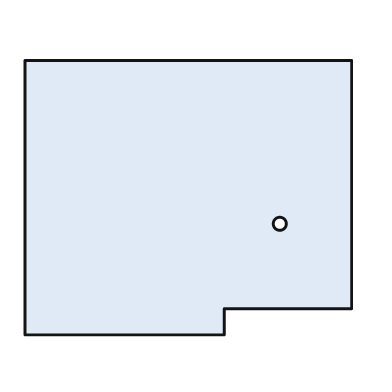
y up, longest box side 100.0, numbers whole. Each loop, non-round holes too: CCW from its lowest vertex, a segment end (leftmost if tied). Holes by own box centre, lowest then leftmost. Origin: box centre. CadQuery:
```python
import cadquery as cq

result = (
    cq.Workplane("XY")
    .moveTo(-50.0, -42.0)
    .lineTo(11.0, -42.0)
    .lineTo(11.0, -34.0)
    .lineTo(50.0, -34.0)
    .lineTo(50.0, 42.0)
    .lineTo(-50.0, 42.0)
    .close()
    .moveTo(28.0, -8.0)
    .circle(2.0)
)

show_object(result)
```